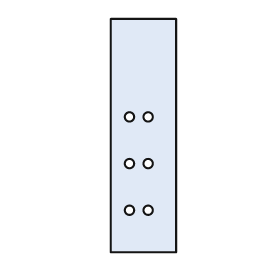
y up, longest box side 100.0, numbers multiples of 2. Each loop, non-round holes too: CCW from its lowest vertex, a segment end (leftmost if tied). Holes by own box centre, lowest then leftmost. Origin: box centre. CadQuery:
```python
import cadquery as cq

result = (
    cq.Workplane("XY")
    .moveTo(-14.0, -50.0)
    .lineTo(14.0, -50.0)
    .lineTo(14.0, 50.0)
    .lineTo(-14.0, 50.0)
    .close()
    .moveTo(-6.0, -32.0)
    .circle(2.0)
    .moveTo(2.0, -32.0)
    .circle(2.0)
    .moveTo(-6.0, -12.0)
    .circle(2.0)
    .moveTo(2.0, -12.0)
    .circle(2.0)
    .moveTo(-6.0, 8.0)
    .circle(2.0)
    .moveTo(2.0, 8.0)
    .circle(2.0)
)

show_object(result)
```